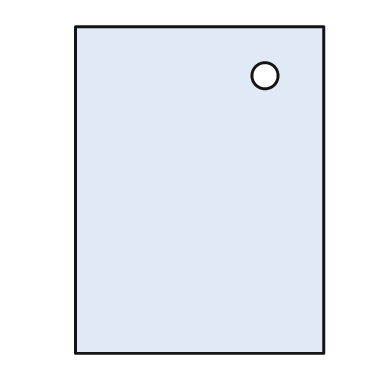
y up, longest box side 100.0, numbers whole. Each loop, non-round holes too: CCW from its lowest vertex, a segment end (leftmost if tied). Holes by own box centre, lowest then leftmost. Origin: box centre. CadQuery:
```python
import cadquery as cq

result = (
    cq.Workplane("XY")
    .moveTo(-38.0, -50.0)
    .lineTo(38.0, -50.0)
    .lineTo(38.0, 50.0)
    .lineTo(-38.0, 50.0)
    .close()
    .moveTo(20.0, 35.0)
    .circle(4.0)
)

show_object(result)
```